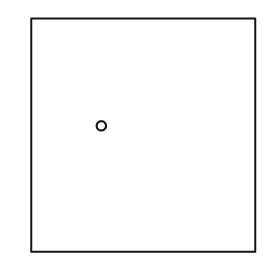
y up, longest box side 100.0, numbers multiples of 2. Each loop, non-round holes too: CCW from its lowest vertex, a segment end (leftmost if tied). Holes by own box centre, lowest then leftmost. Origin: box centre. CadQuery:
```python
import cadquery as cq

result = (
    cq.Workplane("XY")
    .moveTo(-48.0, -50.0)
    .lineTo(48.0, -50.0)
    .lineTo(48.0, 50.0)
    .lineTo(-48.0, 50.0)
    .close()
    .moveTo(-18.0, 4.0)
    .circle(2.0)
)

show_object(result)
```